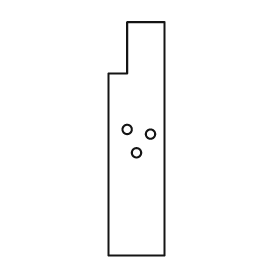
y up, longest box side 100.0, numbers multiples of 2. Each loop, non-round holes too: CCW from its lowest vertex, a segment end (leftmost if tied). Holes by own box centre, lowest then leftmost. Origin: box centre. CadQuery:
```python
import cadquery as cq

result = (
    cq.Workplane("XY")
    .moveTo(-12.0, -50.0)
    .lineTo(12.0, -50.0)
    .lineTo(12.0, 50.0)
    .lineTo(-4.0, 50.0)
    .lineTo(-4.0, 28.0)
    .lineTo(-12.0, 28.0)
    .close()
    .moveTo(0.0, -6.0)
    .circle(2.0)
    .moveTo(6.0, 2.0)
    .circle(2.0)
    .moveTo(-4.0, 4.0)
    .circle(2.0)
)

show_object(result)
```